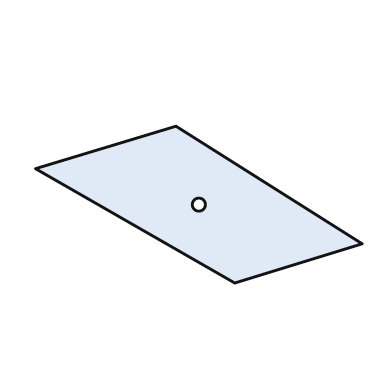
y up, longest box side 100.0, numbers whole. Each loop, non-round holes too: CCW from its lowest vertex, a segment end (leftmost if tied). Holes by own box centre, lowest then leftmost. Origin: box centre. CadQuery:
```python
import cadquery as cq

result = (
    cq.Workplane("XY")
    .moveTo(11.0, -24.0)
    .lineTo(50.0, -12.0)
    .lineTo(-7.0, 24.0)
    .lineTo(-50.0, 11.0)
    .close()
    .moveTo(0.0, 0.0)
    .circle(2.0)
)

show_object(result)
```